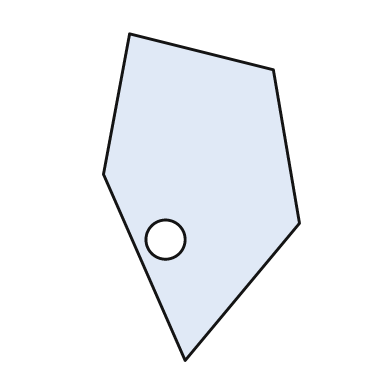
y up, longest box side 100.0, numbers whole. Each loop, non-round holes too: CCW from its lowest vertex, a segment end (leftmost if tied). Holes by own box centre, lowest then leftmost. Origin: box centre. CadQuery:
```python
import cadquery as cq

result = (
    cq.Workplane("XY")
    .moveTo(-5.0, -50.0)
    .lineTo(30.0, -8.0)
    .lineTo(22.0, 39.0)
    .lineTo(-22.0, 50.0)
    .lineTo(-30.0, 7.0)
    .close()
    .moveTo(-11.0, -13.0)
    .circle(6.0)
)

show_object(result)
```